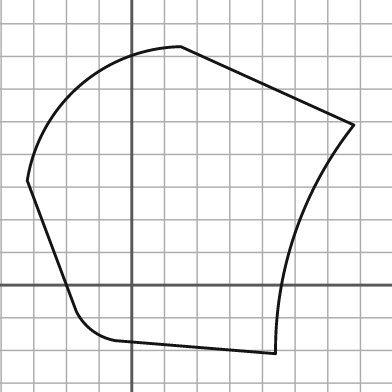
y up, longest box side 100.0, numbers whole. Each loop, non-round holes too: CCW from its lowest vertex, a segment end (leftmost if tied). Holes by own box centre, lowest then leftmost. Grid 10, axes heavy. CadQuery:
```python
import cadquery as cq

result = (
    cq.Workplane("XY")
    .moveTo(44.0, -21.0)
    .threePointArc((50.0, 16.0), (68.0, 49.0))
    .lineTo(15.0, 73.0)
    .threePointArc((-16.0, 61.0), (-32.0, 32.0))
    .lineTo(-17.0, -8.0)
    .threePointArc((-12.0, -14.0), (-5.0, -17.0))
    .close()
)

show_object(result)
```